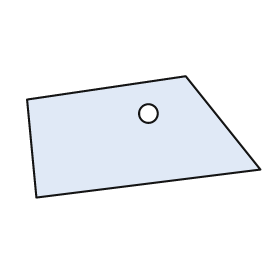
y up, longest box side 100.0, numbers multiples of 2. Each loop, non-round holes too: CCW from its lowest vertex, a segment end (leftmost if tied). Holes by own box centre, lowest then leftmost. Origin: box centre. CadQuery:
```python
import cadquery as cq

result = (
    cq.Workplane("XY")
    .moveTo(-46.0, -26.0)
    .lineTo(50.0, -14.0)
    .lineTo(18.0, 26.0)
    .lineTo(-50.0, 16.0)
    .close()
    .moveTo(2.0, 10.0)
    .circle(4.0)
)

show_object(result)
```